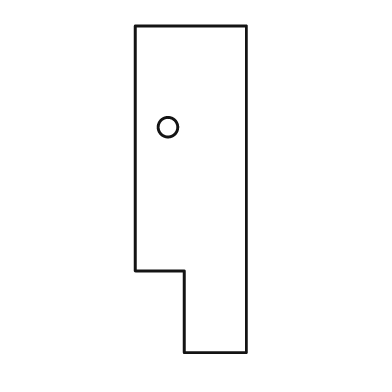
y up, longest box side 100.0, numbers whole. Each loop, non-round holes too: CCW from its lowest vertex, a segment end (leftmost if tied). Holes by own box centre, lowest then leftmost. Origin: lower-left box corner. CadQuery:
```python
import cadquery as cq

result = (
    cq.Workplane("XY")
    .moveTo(15.0, 0.0)
    .lineTo(34.0, 0.0)
    .lineTo(34.0, 100.0)
    .lineTo(0.0, 100.0)
    .lineTo(0.0, 25.0)
    .lineTo(15.0, 25.0)
    .close()
    .moveTo(10.0, 69.0)
    .circle(3.0)
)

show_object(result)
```